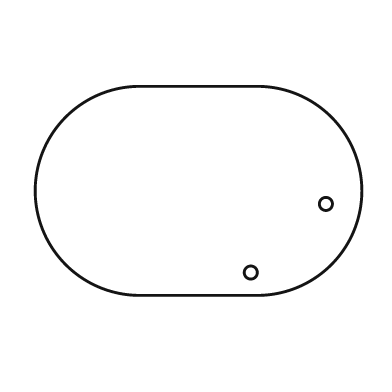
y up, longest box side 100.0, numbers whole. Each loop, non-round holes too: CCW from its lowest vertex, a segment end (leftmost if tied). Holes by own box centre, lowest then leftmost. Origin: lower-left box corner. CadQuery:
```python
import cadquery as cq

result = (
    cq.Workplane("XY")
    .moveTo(32.0, 0.0)
    .lineTo(68.0, 0.0)
    .threePointArc((100.0, 32.0), (68.0, 64.0))
    .lineTo(32.0, 64.0)
    .threePointArc((0.0, 32.0), (32.0, 0.0))
    .close()
    .moveTo(66.0, 7.0)
    .circle(2.0)
    .moveTo(89.0, 28.0)
    .circle(2.0)
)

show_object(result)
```